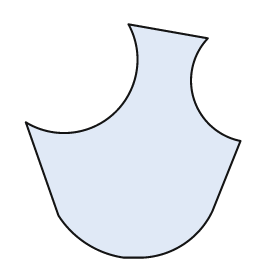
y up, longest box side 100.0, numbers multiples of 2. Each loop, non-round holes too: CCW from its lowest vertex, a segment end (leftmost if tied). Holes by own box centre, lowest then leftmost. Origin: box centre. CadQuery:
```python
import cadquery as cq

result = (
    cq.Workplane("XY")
    .moveTo(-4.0, -50.0)
    .lineTo(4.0, -50.0)
    .threePointArc((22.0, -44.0), (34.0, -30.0))
    .lineTo(46.0, 0.0)
    .threePointArc((26.0, 18.0), (32.0, 44.0))
    .lineTo(-2.0, 50.0)
    .threePointArc((-8.0, 12.0), (-46.0, 8.0))
    .lineTo(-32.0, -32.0)
    .threePointArc((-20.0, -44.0), (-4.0, -50.0))
    .close()
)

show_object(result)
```